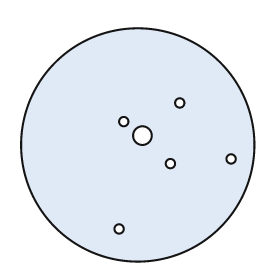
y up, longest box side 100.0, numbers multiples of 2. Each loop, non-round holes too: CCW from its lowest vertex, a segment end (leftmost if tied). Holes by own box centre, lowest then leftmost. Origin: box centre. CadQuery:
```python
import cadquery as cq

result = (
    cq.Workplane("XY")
    .moveTo(0.0, 0.0)
    .circle(50.0)
    .moveTo(-8.0, -36.0)
    .circle(2.0)
    .moveTo(14.0, -8.0)
    .circle(2.0)
    .moveTo(40.0, -6.0)
    .circle(2.0)
    .moveTo(2.0, 4.0)
    .circle(4.0)
    .moveTo(-6.0, 10.0)
    .circle(2.0)
    .moveTo(18.0, 18.0)
    .circle(2.0)
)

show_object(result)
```